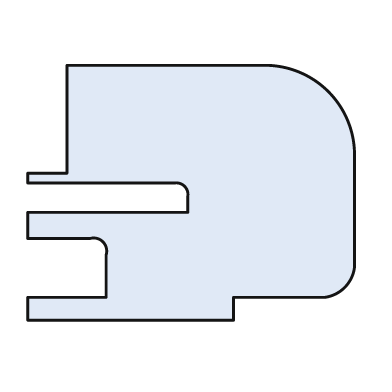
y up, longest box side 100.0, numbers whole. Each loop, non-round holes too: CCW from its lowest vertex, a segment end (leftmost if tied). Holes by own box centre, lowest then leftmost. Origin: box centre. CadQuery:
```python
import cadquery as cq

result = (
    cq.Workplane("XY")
    .moveTo(-50.0, -39.0)
    .lineTo(13.0, -39.0)
    .lineTo(13.0, -32.0)
    .lineTo(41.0, -32.0)
    .threePointArc((47.0, -29.0), (50.0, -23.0))
    .lineTo(50.0, 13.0)
    .threePointArc((42.0, 31.0), (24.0, 39.0))
    .lineTo(-38.0, 39.0)
    .lineTo(-38.0, 6.0)
    .lineTo(-50.0, 6.0)
    .lineTo(-50.0, 3.0)
    .lineTo(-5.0, 3.0)
    .threePointArc((-2.0, 2.0), (-1.0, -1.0))
    .lineTo(-1.0, -6.0)
    .lineTo(-50.0, -6.0)
    .lineTo(-50.0, -14.0)
    .lineTo(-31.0, -14.0)
    .threePointArc((-27.0, -15.0), (-26.0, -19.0))
    .lineTo(-26.0, -32.0)
    .lineTo(-50.0, -32.0)
    .close()
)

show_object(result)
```